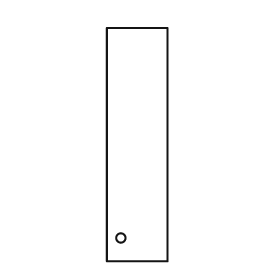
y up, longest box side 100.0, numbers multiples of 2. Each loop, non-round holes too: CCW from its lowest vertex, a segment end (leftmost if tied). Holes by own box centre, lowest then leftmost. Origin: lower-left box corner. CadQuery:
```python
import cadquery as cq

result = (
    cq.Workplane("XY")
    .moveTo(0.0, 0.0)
    .lineTo(26.0, 0.0)
    .lineTo(26.0, 100.0)
    .lineTo(0.0, 100.0)
    .close()
    .moveTo(6.0, 10.0)
    .circle(2.0)
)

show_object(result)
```